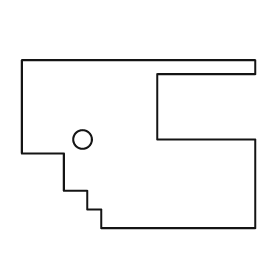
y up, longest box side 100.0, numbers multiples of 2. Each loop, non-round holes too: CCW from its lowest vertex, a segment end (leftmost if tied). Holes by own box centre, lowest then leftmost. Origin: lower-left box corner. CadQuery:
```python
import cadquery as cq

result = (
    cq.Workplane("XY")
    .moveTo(34.0, 0.0)
    .lineTo(100.0, 0.0)
    .lineTo(100.0, 38.0)
    .lineTo(58.0, 38.0)
    .lineTo(58.0, 66.0)
    .lineTo(100.0, 66.0)
    .lineTo(100.0, 72.0)
    .lineTo(0.0, 72.0)
    .lineTo(0.0, 32.0)
    .lineTo(18.0, 32.0)
    .lineTo(18.0, 16.0)
    .lineTo(28.0, 16.0)
    .lineTo(28.0, 8.0)
    .lineTo(34.0, 8.0)
    .close()
    .moveTo(26.0, 38.0)
    .circle(4.0)
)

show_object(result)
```